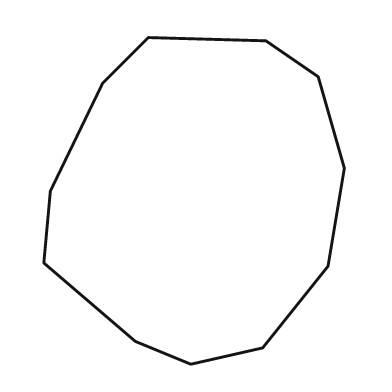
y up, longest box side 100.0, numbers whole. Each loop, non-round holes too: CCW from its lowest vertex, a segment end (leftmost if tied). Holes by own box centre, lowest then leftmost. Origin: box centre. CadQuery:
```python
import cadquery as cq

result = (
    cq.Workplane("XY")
    .moveTo(-1.0, -50.0)
    .lineTo(21.0, -45.0)
    .lineTo(41.0, -20.0)
    .lineTo(46.0, 10.0)
    .lineTo(38.0, 38.0)
    .lineTo(22.0, 49.0)
    .lineTo(-14.0, 50.0)
    .lineTo(-28.0, 36.0)
    .lineTo(-44.0, 3.0)
    .lineTo(-46.0, -19.0)
    .lineTo(-18.0, -43.0)
    .close()
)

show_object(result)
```